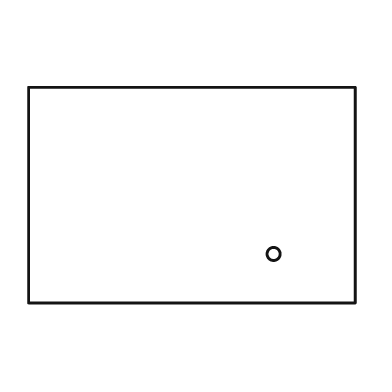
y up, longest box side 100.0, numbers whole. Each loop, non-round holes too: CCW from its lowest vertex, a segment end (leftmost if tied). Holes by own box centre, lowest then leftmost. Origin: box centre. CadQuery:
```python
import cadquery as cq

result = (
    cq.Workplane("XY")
    .moveTo(-50.0, -33.0)
    .lineTo(50.0, -33.0)
    .lineTo(50.0, 33.0)
    .lineTo(-50.0, 33.0)
    .close()
    .moveTo(25.0, -18.0)
    .circle(2.0)
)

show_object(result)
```